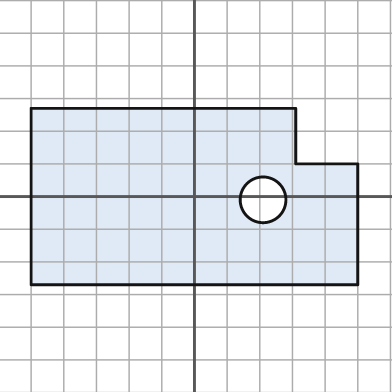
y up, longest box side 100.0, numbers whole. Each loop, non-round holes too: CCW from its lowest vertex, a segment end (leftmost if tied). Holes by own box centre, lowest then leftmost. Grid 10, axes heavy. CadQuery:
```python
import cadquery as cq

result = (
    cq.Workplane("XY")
    .moveTo(-50.0, -27.0)
    .lineTo(50.0, -27.0)
    .lineTo(50.0, 10.0)
    .lineTo(31.0, 10.0)
    .lineTo(31.0, 27.0)
    .lineTo(-50.0, 27.0)
    .close()
    .moveTo(21.0, -1.0)
    .circle(7.0)
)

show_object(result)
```